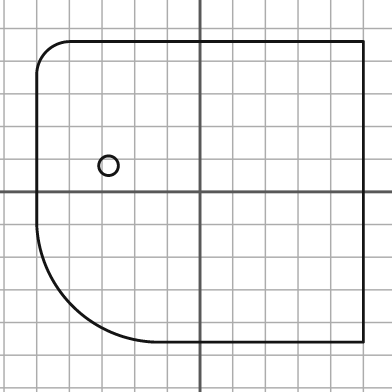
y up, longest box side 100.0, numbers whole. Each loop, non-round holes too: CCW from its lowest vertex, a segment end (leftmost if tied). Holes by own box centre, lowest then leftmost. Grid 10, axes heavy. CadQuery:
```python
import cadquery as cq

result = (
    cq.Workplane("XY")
    .moveTo(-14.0, -46.0)
    .lineTo(50.0, -46.0)
    .lineTo(50.0, 46.0)
    .lineTo(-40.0, 46.0)
    .threePointArc((-47.0, 43.0), (-50.0, 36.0))
    .lineTo(-50.0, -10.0)
    .threePointArc((-39.0, -35.0), (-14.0, -46.0))
    .close()
    .moveTo(-28.0, 8.0)
    .circle(3.0)
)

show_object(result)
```